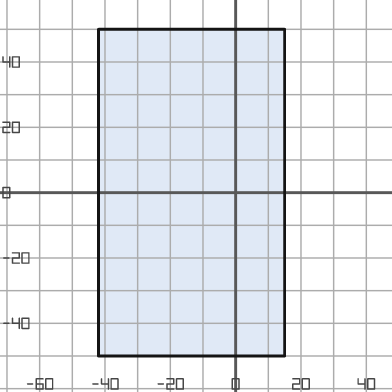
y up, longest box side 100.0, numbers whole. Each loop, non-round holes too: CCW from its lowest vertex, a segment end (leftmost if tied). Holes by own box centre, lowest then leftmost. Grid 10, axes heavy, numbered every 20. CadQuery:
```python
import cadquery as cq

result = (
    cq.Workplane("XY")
    .moveTo(-42.0, -50.0)
    .lineTo(15.0, -50.0)
    .lineTo(15.0, 50.0)
    .lineTo(-42.0, 50.0)
    .close()
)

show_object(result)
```